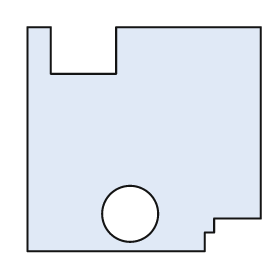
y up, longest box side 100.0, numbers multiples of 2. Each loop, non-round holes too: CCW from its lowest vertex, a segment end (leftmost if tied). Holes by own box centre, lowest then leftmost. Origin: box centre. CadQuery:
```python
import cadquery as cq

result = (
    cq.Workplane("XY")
    .moveTo(-50.0, -48.0)
    .lineTo(26.0, -48.0)
    .lineTo(26.0, -40.0)
    .lineTo(30.0, -40.0)
    .lineTo(30.0, -34.0)
    .lineTo(50.0, -34.0)
    .lineTo(50.0, 48.0)
    .lineTo(-12.0, 48.0)
    .lineTo(-12.0, 28.0)
    .lineTo(-40.0, 28.0)
    .lineTo(-40.0, 48.0)
    .lineTo(-50.0, 48.0)
    .close()
    .moveTo(-6.0, -32.0)
    .circle(12.0)
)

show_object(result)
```